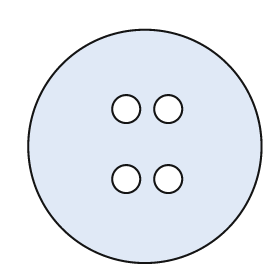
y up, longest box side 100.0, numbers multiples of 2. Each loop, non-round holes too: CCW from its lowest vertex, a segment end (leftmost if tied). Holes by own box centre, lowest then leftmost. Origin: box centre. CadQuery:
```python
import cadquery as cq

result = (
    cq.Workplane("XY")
    .moveTo(0.0, 0.0)
    .circle(50.0)
    .moveTo(-8.0, -14.0)
    .circle(6.0)
    .moveTo(10.0, -14.0)
    .circle(6.0)
    .moveTo(-8.0, 16.0)
    .circle(6.0)
    .moveTo(10.0, 16.0)
    .circle(6.0)
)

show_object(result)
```